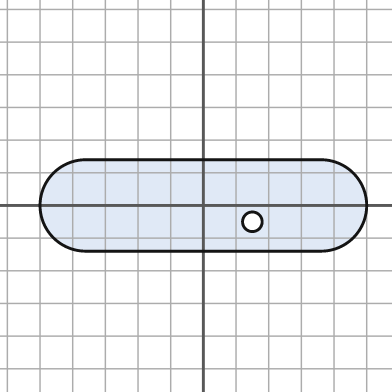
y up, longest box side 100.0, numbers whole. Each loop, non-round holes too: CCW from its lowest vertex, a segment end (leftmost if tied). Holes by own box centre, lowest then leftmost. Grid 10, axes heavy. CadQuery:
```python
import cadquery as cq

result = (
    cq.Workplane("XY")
    .moveTo(-36.0, -14.0)
    .lineTo(36.0, -14.0)
    .threePointArc((50.0, 0.0), (36.0, 14.0))
    .lineTo(-36.0, 14.0)
    .threePointArc((-50.0, 0.0), (-36.0, -14.0))
    .close()
    .moveTo(15.0, -5.0)
    .circle(3.0)
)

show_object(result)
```